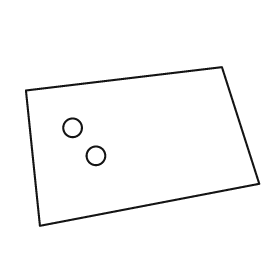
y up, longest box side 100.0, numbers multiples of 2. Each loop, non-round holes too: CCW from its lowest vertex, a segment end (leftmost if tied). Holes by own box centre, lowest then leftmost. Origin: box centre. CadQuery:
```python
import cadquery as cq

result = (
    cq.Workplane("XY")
    .moveTo(-44.0, -34.0)
    .lineTo(50.0, -16.0)
    .lineTo(34.0, 34.0)
    .lineTo(-50.0, 24.0)
    .close()
    .moveTo(-20.0, -4.0)
    .circle(4.0)
    .moveTo(-30.0, 8.0)
    .circle(4.0)
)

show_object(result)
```